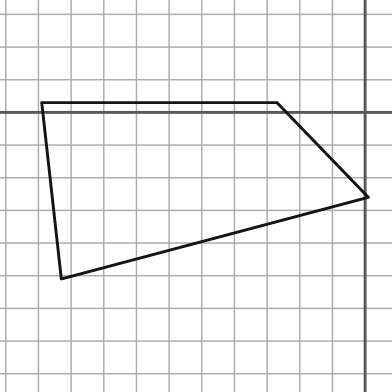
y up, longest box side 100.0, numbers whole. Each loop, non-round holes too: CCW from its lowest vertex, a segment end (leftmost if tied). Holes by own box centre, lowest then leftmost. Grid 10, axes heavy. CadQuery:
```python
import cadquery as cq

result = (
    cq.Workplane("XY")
    .moveTo(-93.0, -51.0)
    .lineTo(1.0, -26.0)
    .lineTo(-27.0, 3.0)
    .lineTo(-99.0, 3.0)
    .close()
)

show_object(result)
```